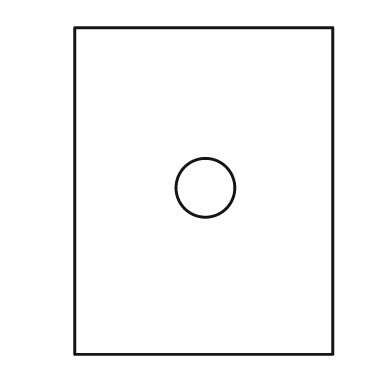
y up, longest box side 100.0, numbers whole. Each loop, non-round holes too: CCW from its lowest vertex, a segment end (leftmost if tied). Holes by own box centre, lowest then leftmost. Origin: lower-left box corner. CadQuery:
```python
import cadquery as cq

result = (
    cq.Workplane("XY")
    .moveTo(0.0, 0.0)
    .lineTo(79.0, 0.0)
    .lineTo(79.0, 100.0)
    .lineTo(0.0, 100.0)
    .close()
    .moveTo(40.0, 51.0)
    .circle(9.0)
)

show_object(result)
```